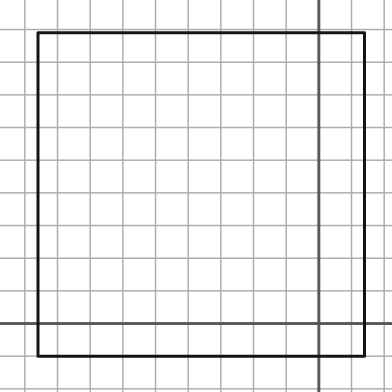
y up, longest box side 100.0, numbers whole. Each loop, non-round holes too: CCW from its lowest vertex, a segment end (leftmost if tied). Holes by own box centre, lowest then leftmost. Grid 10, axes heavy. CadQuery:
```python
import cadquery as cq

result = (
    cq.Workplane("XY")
    .moveTo(-86.0, -10.0)
    .lineTo(14.0, -10.0)
    .lineTo(14.0, 89.0)
    .lineTo(-86.0, 89.0)
    .close()
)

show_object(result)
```